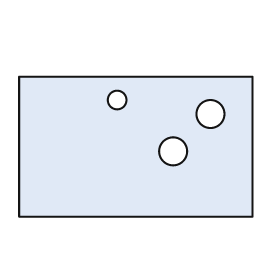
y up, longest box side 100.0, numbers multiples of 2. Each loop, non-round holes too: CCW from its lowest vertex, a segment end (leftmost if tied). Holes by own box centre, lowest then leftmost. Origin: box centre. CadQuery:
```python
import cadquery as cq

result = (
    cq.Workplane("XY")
    .moveTo(-50.0, -30.0)
    .lineTo(50.0, -30.0)
    .lineTo(50.0, 30.0)
    .lineTo(-50.0, 30.0)
    .close()
    .moveTo(16.0, -2.0)
    .circle(6.0)
    .moveTo(32.0, 14.0)
    .circle(6.0)
    .moveTo(-8.0, 20.0)
    .circle(4.0)
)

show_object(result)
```